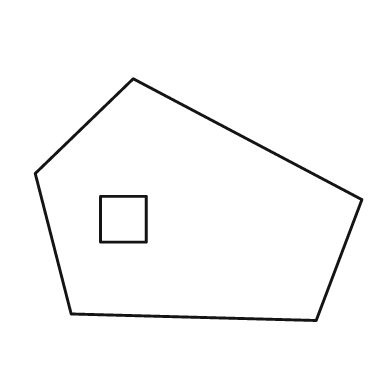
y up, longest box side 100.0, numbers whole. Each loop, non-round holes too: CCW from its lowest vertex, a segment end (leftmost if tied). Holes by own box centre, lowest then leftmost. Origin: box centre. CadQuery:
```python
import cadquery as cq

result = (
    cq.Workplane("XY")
    .moveTo(36.0, -37.0)
    .lineTo(50.0, 0.0)
    .lineTo(-20.0, 37.0)
    .lineTo(-50.0, 8.0)
    .lineTo(-39.0, -35.0)
    .close()
    .moveTo(-30.0, -13.0)
    .lineTo(-16.0, -13.0)
    .lineTo(-16.0, 1.0)
    .lineTo(-30.0, 1.0)
    .close()
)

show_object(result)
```